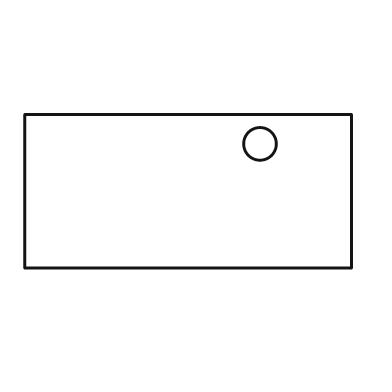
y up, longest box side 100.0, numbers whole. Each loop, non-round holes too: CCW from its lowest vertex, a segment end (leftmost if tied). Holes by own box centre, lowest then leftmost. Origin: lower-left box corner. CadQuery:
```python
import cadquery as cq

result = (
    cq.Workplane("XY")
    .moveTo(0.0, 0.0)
    .lineTo(100.0, 0.0)
    .lineTo(100.0, 47.0)
    .lineTo(0.0, 47.0)
    .close()
    .moveTo(72.0, 38.0)
    .circle(5.0)
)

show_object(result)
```